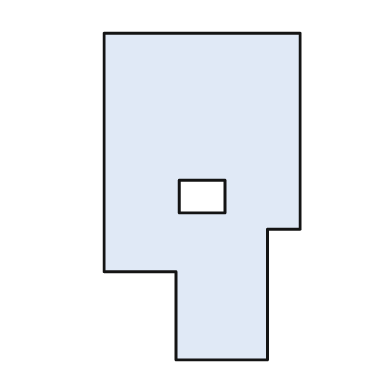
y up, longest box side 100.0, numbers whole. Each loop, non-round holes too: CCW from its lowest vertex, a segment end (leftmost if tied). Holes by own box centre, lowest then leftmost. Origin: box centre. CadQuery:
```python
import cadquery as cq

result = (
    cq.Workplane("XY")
    .moveTo(-8.0, -50.0)
    .lineTo(20.0, -50.0)
    .lineTo(20.0, -10.0)
    .lineTo(30.0, -10.0)
    .lineTo(30.0, 50.0)
    .lineTo(-30.0, 50.0)
    .lineTo(-30.0, -23.0)
    .lineTo(-8.0, -23.0)
    .close()
    .moveTo(-7.0, -5.0)
    .lineTo(7.0, -5.0)
    .lineTo(7.0, 5.0)
    .lineTo(-7.0, 5.0)
    .close()
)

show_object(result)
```